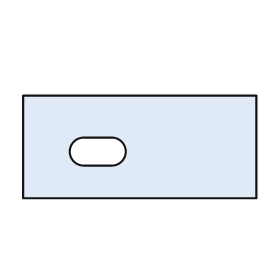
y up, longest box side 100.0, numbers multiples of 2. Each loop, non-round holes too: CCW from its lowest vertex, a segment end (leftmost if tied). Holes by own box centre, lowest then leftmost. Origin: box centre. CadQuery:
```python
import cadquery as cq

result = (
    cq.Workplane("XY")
    .moveTo(-50.0, -22.0)
    .lineTo(50.0, -22.0)
    .lineTo(50.0, 22.0)
    .lineTo(-50.0, 22.0)
    .close()
    .moveTo(-24.0, -8.0)
    .lineTo(-12.0, -8.0)
    .threePointArc((-6.0, -2.0), (-12.0, 4.0))
    .lineTo(-24.0, 4.0)
    .threePointArc((-30.0, -2.0), (-24.0, -8.0))
    .close()
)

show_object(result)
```